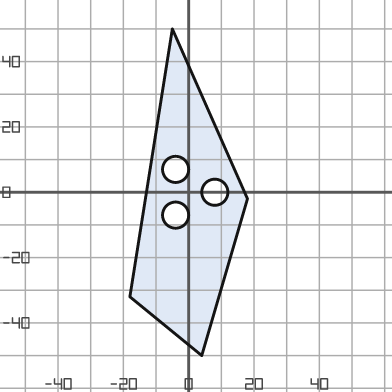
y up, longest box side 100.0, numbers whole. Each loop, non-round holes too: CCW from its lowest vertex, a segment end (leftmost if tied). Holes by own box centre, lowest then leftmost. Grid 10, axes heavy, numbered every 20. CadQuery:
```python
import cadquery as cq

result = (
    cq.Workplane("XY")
    .moveTo(4.0, -50.0)
    .lineTo(18.0, -2.0)
    .lineTo(-5.0, 50.0)
    .lineTo(-18.0, -32.0)
    .close()
    .moveTo(-4.0, -7.0)
    .circle(4.0)
    .moveTo(8.0, 0.0)
    .circle(4.0)
    .moveTo(-4.0, 7.0)
    .circle(4.0)
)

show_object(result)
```